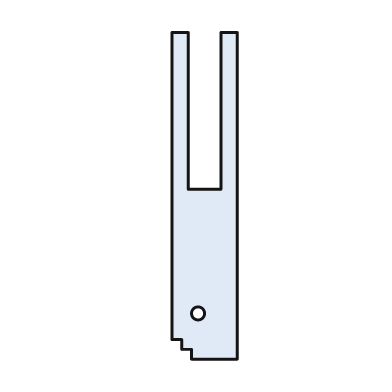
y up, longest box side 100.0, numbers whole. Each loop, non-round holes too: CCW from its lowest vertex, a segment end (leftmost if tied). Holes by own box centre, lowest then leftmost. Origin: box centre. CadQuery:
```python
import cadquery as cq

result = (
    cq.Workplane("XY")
    .moveTo(-4.0, -50.0)
    .lineTo(10.0, -50.0)
    .lineTo(10.0, 50.0)
    .lineTo(5.0, 50.0)
    .lineTo(5.0, 2.0)
    .lineTo(-5.0, 2.0)
    .lineTo(-5.0, 50.0)
    .lineTo(-10.0, 50.0)
    .lineTo(-10.0, -44.0)
    .lineTo(-7.0, -44.0)
    .lineTo(-7.0, -47.0)
    .lineTo(-4.0, -47.0)
    .close()
    .moveTo(-2.0, -36.0)
    .circle(2.0)
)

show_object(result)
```